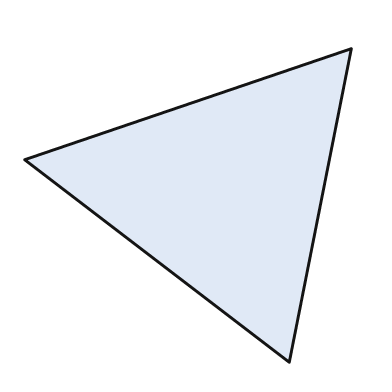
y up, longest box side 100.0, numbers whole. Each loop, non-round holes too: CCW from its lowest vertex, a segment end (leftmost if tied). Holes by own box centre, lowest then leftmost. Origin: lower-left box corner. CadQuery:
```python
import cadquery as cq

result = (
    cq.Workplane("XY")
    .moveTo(81.0, 0.0)
    .lineTo(100.0, 96.0)
    .lineTo(0.0, 62.0)
    .close()
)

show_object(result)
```